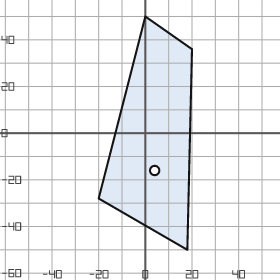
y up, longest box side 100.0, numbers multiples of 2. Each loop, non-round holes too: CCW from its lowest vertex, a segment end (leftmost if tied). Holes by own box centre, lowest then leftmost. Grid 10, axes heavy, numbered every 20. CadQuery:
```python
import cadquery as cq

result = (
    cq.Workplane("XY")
    .moveTo(18.0, -50.0)
    .lineTo(20.0, 36.0)
    .lineTo(0.0, 50.0)
    .lineTo(-20.0, -28.0)
    .close()
    .moveTo(4.0, -16.0)
    .circle(2.0)
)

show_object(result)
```